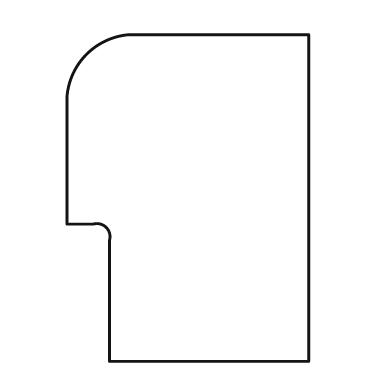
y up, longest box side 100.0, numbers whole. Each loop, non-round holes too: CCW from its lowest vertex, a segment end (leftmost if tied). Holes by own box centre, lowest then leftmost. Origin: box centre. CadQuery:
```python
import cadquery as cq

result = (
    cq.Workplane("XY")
    .moveTo(-24.0, -50.0)
    .lineTo(37.0, -50.0)
    .lineTo(37.0, 50.0)
    .lineTo(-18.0, 50.0)
    .threePointArc((-31.0, 44.0), (-37.0, 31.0))
    .lineTo(-37.0, -8.0)
    .lineTo(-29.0, -8.0)
    .threePointArc((-25.0, -9.0), (-24.0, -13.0))
    .close()
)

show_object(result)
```